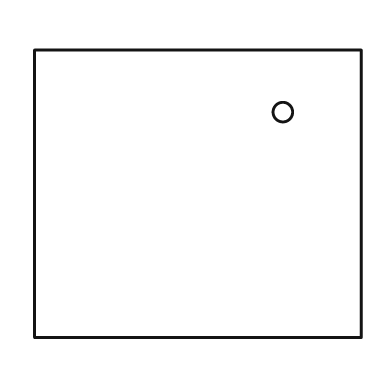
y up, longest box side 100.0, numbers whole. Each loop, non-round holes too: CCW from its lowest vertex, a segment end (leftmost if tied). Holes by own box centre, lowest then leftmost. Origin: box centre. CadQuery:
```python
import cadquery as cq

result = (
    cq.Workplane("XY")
    .moveTo(-50.0, -44.0)
    .lineTo(50.0, -44.0)
    .lineTo(50.0, 44.0)
    .lineTo(-50.0, 44.0)
    .close()
    .moveTo(26.0, 25.0)
    .circle(3.0)
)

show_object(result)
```